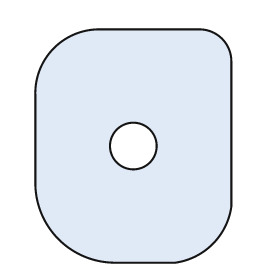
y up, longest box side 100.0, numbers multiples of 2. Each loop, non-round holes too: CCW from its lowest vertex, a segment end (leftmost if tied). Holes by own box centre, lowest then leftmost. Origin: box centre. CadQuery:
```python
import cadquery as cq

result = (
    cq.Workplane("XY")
    .moveTo(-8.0, -50.0)
    .lineTo(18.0, -50.0)
    .threePointArc((34.0, -42.0), (42.0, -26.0))
    .lineTo(42.0, 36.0)
    .threePointArc((38.0, 46.0), (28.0, 50.0))
    .lineTo(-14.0, 50.0)
    .threePointArc((-34.0, 42.0), (-42.0, 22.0))
    .lineTo(-42.0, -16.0)
    .threePointArc((-32.0, -40.0), (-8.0, -50.0))
    .close()
    .moveTo(0.0, 0.0)
    .circle(10.0)
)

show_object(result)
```